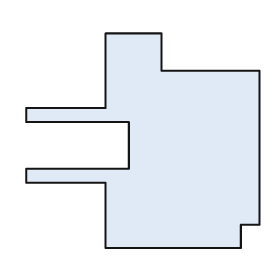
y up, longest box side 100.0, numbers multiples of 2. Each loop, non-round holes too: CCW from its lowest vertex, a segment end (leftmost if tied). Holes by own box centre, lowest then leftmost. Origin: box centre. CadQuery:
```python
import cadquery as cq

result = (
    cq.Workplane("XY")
    .moveTo(-16.0, -46.0)
    .lineTo(42.0, -46.0)
    .lineTo(42.0, -36.0)
    .lineTo(50.0, -36.0)
    .lineTo(50.0, 30.0)
    .lineTo(8.0, 30.0)
    .lineTo(8.0, 46.0)
    .lineTo(-16.0, 46.0)
    .lineTo(-16.0, 14.0)
    .lineTo(-50.0, 14.0)
    .lineTo(-50.0, 8.0)
    .lineTo(-6.0, 8.0)
    .lineTo(-6.0, -12.0)
    .lineTo(-50.0, -12.0)
    .lineTo(-50.0, -18.0)
    .lineTo(-16.0, -18.0)
    .close()
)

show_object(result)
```